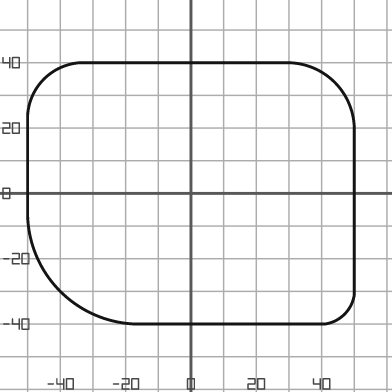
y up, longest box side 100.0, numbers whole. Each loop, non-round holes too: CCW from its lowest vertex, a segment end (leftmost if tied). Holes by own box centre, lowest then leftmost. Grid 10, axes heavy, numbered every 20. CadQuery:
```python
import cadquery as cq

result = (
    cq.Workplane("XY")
    .moveTo(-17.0, -40.0)
    .lineTo(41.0, -40.0)
    .threePointArc((47.0, -37.0), (50.0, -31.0))
    .lineTo(50.0, 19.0)
    .threePointArc((44.0, 34.0), (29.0, 40.0))
    .lineTo(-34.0, 40.0)
    .threePointArc((-45.0, 35.0), (-50.0, 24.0))
    .lineTo(-50.0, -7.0)
    .threePointArc((-40.0, -30.0), (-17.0, -40.0))
    .close()
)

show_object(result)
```